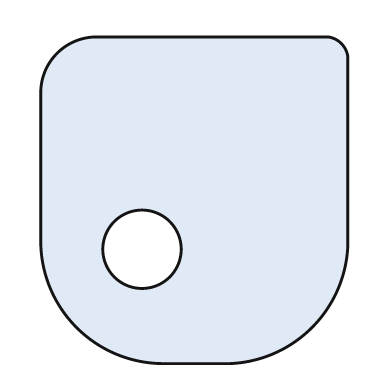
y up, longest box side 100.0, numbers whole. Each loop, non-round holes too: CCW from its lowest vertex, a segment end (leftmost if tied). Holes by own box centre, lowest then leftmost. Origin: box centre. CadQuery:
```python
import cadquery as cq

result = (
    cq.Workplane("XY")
    .moveTo(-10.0, -50.0)
    .lineTo(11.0, -50.0)
    .threePointArc((36.0, -39.0), (47.0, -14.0))
    .lineTo(47.0, 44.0)
    .threePointArc((45.0, 48.0), (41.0, 50.0))
    .lineTo(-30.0, 50.0)
    .threePointArc((-42.0, 45.0), (-47.0, 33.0))
    .lineTo(-47.0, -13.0)
    .threePointArc((-36.0, -39.0), (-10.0, -50.0))
    .close()
    .moveTo(-16.0, -15.0)
    .circle(12.0)
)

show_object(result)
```